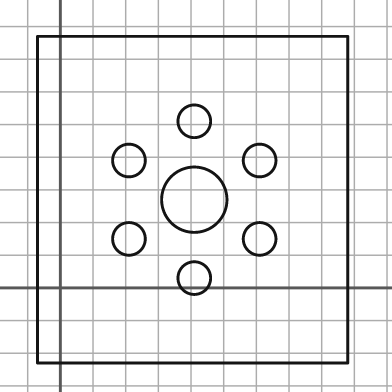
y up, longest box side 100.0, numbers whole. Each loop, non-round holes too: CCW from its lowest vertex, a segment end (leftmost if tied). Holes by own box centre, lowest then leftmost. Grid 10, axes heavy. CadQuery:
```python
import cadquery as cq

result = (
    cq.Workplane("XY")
    .moveTo(-7.0, -23.0)
    .lineTo(88.0, -23.0)
    .lineTo(88.0, 77.0)
    .lineTo(-7.0, 77.0)
    .close()
    .moveTo(41.0, 3.0)
    .circle(5.0)
    .moveTo(21.0, 15.0)
    .circle(5.0)
    .moveTo(61.0, 15.0)
    .circle(5.0)
    .moveTo(41.0, 27.0)
    .circle(10.0)
    .moveTo(21.0, 39.0)
    .circle(5.0)
    .moveTo(61.0, 39.0)
    .circle(5.0)
    .moveTo(41.0, 51.0)
    .circle(5.0)
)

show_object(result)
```